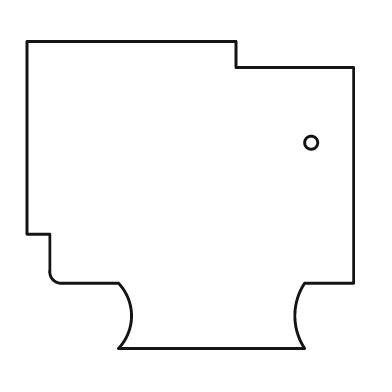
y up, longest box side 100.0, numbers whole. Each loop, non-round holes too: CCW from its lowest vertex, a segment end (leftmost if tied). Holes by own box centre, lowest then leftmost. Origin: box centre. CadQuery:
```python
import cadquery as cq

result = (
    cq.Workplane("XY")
    .moveTo(-22.0, -47.0)
    .lineTo(35.0, -47.0)
    .threePointArc((32.0, -37.0), (35.0, -27.0))
    .lineTo(50.0, -27.0)
    .lineTo(50.0, 39.0)
    .lineTo(14.0, 39.0)
    .lineTo(14.0, 47.0)
    .lineTo(-50.0, 47.0)
    .lineTo(-50.0, -12.0)
    .lineTo(-43.0, -12.0)
    .lineTo(-43.0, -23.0)
    .threePointArc((-42.0, -26.0), (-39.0, -27.0))
    .lineTo(-22.0, -27.0)
    .threePointArc((-18.0, -37.0), (-22.0, -47.0))
    .close()
    .moveTo(37.0, 16.0)
    .circle(2.0)
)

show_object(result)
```